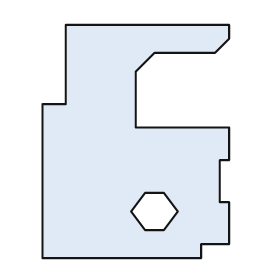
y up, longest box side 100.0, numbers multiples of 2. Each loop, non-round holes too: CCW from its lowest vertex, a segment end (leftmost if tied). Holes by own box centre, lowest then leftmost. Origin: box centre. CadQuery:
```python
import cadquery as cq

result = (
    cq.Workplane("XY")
    .moveTo(-40.0, -50.0)
    .lineTo(28.0, -50.0)
    .lineTo(28.0, -44.0)
    .lineTo(40.0, -44.0)
    .lineTo(40.0, -26.0)
    .lineTo(36.0, -26.0)
    .lineTo(36.0, -8.0)
    .lineTo(40.0, -8.0)
    .lineTo(40.0, 6.0)
    .lineTo(0.0, 6.0)
    .lineTo(0.0, 30.0)
    .lineTo(8.0, 38.0)
    .lineTo(34.0, 38.0)
    .lineTo(40.0, 44.0)
    .lineTo(40.0, 50.0)
    .lineTo(-30.0, 50.0)
    .lineTo(-30.0, 16.0)
    .lineTo(-40.0, 16.0)
    .close()
    .moveTo(4.0, -38.0)
    .lineTo(12.0, -38.0)
    .lineTo(18.0, -30.0)
    .lineTo(12.0, -22.0)
    .lineTo(4.0, -22.0)
    .lineTo(-2.0, -30.0)
    .close()
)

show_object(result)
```